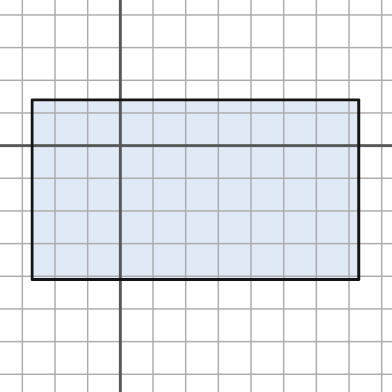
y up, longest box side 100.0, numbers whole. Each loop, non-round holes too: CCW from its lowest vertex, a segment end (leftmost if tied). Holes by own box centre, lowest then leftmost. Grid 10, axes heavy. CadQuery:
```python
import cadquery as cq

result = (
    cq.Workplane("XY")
    .moveTo(-27.0, -41.0)
    .lineTo(73.0, -41.0)
    .lineTo(73.0, 14.0)
    .lineTo(-27.0, 14.0)
    .close()
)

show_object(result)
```